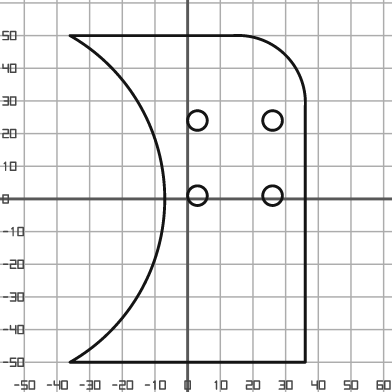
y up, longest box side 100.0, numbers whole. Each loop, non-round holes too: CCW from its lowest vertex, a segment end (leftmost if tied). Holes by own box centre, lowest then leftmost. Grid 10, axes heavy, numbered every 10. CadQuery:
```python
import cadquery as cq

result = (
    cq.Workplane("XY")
    .moveTo(-36.0, -50.0)
    .lineTo(36.0, -50.0)
    .lineTo(36.0, 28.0)
    .threePointArc((30.0, 44.0), (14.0, 50.0))
    .lineTo(-36.0, 50.0)
    .threePointArc((-7.0, 0.0), (-36.0, -50.0))
    .close()
    .moveTo(3.0, 1.0)
    .circle(3.0)
    .moveTo(26.0, 1.0)
    .circle(3.0)
    .moveTo(3.0, 24.0)
    .circle(3.0)
    .moveTo(26.0, 24.0)
    .circle(3.0)
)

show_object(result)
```